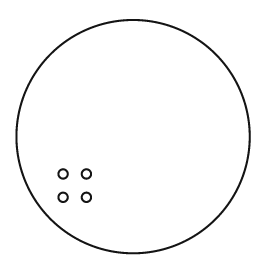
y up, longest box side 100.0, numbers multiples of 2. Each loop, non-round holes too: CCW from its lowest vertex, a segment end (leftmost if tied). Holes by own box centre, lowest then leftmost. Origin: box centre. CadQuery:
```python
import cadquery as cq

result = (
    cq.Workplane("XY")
    .moveTo(0.0, 0.0)
    .circle(50.0)
    .moveTo(-30.0, -26.0)
    .circle(2.0)
    .moveTo(-20.0, -26.0)
    .circle(2.0)
    .moveTo(-30.0, -16.0)
    .circle(2.0)
    .moveTo(-20.0, -16.0)
    .circle(2.0)
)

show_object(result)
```